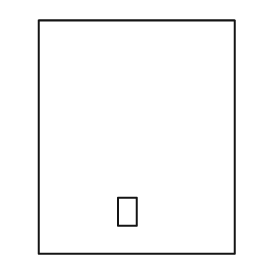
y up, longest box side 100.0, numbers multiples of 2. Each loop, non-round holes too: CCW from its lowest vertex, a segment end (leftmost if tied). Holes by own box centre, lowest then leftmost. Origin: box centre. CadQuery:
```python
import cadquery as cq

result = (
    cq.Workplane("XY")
    .moveTo(-42.0, -50.0)
    .lineTo(42.0, -50.0)
    .lineTo(42.0, 50.0)
    .lineTo(-42.0, 50.0)
    .close()
    .moveTo(-8.0, -38.0)
    .lineTo(0.0, -38.0)
    .lineTo(0.0, -26.0)
    .lineTo(-8.0, -26.0)
    .close()
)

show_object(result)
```